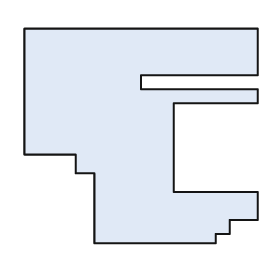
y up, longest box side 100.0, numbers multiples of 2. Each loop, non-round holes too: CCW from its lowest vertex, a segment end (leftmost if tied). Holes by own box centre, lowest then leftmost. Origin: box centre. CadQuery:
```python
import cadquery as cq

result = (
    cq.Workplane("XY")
    .moveTo(-20.0, -46.0)
    .lineTo(32.0, -46.0)
    .lineTo(32.0, -42.0)
    .lineTo(38.0, -42.0)
    .lineTo(38.0, -36.0)
    .lineTo(50.0, -36.0)
    .lineTo(50.0, -24.0)
    .lineTo(14.0, -24.0)
    .lineTo(14.0, 14.0)
    .lineTo(50.0, 14.0)
    .lineTo(50.0, 20.0)
    .lineTo(0.0, 20.0)
    .lineTo(0.0, 26.0)
    .lineTo(50.0, 26.0)
    .lineTo(50.0, 46.0)
    .lineTo(-50.0, 46.0)
    .lineTo(-50.0, -8.0)
    .lineTo(-28.0, -8.0)
    .lineTo(-28.0, -16.0)
    .lineTo(-20.0, -16.0)
    .close()
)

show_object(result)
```